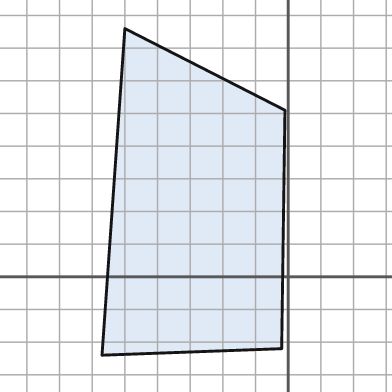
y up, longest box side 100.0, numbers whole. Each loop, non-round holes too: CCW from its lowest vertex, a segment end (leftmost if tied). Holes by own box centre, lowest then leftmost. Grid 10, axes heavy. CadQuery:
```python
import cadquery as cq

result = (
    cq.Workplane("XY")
    .moveTo(-57.0, -24.0)
    .lineTo(-2.0, -22.0)
    .lineTo(-1.0, 51.0)
    .lineTo(-50.0, 76.0)
    .close()
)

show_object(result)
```